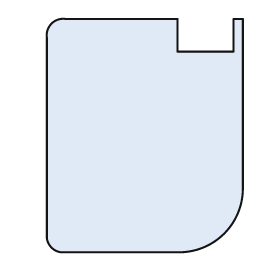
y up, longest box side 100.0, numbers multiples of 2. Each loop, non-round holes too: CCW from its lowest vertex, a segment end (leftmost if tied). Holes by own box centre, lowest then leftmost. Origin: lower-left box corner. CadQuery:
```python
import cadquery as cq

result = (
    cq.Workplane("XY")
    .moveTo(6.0, 0.0)
    .lineTo(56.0, 0.0)
    .threePointArc((76.0, 8.0), (84.0, 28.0))
    .lineTo(84.0, 100.0)
    .lineTo(80.0, 100.0)
    .lineTo(80.0, 86.0)
    .lineTo(56.0, 86.0)
    .lineTo(56.0, 100.0)
    .lineTo(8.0, 100.0)
    .threePointArc((2.0, 98.0), (0.0, 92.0))
    .lineTo(0.0, 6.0)
    .threePointArc((2.0, 2.0), (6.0, 0.0))
    .close()
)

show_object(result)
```